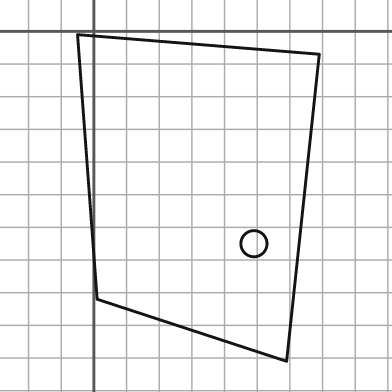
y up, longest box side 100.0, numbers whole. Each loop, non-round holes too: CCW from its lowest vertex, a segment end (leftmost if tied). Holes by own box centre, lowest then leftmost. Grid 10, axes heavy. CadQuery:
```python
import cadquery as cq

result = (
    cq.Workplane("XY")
    .moveTo(59.0, -101.0)
    .lineTo(69.0, -7.0)
    .lineTo(-5.0, -1.0)
    .lineTo(1.0, -82.0)
    .close()
    .moveTo(49.0, -65.0)
    .circle(4.0)
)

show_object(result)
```